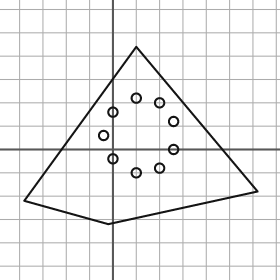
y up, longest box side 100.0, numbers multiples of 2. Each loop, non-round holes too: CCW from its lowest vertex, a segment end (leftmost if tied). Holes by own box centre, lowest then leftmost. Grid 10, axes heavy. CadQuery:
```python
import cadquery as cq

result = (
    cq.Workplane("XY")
    .moveTo(-2.0, -32.0)
    .lineTo(62.0, -18.0)
    .lineTo(10.0, 44.0)
    .lineTo(-38.0, -22.0)
    .close()
    .moveTo(10.0, -10.0)
    .circle(2.0)
    .moveTo(20.0, -8.0)
    .circle(2.0)
    .moveTo(0.0, -4.0)
    .circle(2.0)
    .moveTo(26.0, 0.0)
    .circle(2.0)
    .moveTo(-4.0, 6.0)
    .circle(2.0)
    .moveTo(26.0, 12.0)
    .circle(2.0)
    .moveTo(0.0, 16.0)
    .circle(2.0)
    .moveTo(20.0, 20.0)
    .circle(2.0)
    .moveTo(10.0, 22.0)
    .circle(2.0)
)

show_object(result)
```